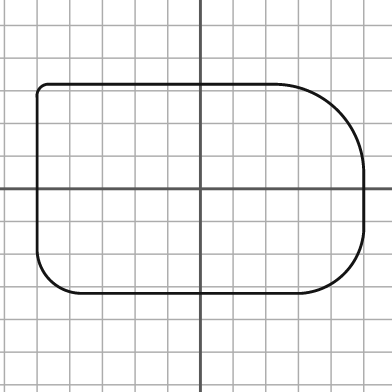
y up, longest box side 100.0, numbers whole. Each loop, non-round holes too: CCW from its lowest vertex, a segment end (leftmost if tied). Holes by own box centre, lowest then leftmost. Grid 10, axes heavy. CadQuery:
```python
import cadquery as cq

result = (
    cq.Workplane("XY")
    .moveTo(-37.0, -32.0)
    .lineTo(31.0, -32.0)
    .threePointArc((44.0, -26.0), (50.0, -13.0))
    .lineTo(50.0, 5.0)
    .threePointArc((42.0, 24.0), (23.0, 32.0))
    .lineTo(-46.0, 32.0)
    .threePointArc((-49.0, 31.0), (-50.0, 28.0))
    .lineTo(-50.0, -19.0)
    .threePointArc((-46.0, -28.0), (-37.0, -32.0))
    .close()
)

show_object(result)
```